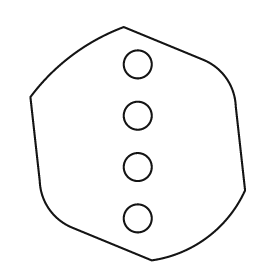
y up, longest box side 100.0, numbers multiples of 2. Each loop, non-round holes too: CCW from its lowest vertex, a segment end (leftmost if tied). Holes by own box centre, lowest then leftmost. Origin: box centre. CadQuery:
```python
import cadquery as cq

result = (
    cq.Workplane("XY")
    .moveTo(6.0, -50.0)
    .threePointArc((30.0, -40.0), (46.0, -20.0))
    .lineTo(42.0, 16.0)
    .threePointArc((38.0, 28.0), (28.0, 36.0))
    .lineTo(-6.0, 50.0)
    .threePointArc((-28.0, 38.0), (-46.0, 20.0))
    .lineTo(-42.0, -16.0)
    .threePointArc((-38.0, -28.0), (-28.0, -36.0))
    .close()
    .moveTo(0.0, -32.0)
    .circle(6.0)
    .moveTo(0.0, -10.0)
    .circle(6.0)
    .moveTo(0.0, 12.0)
    .circle(6.0)
    .moveTo(0.0, 34.0)
    .circle(6.0)
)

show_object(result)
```